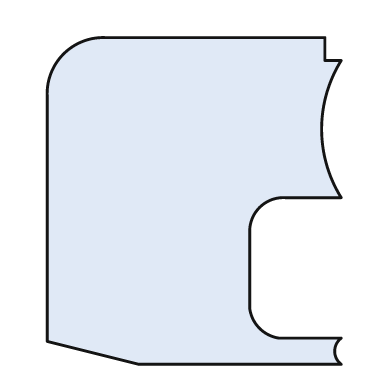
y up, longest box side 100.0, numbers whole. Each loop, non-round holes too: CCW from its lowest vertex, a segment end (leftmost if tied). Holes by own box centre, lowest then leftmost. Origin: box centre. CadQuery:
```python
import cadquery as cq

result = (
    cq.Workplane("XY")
    .moveTo(-17.0, -50.0)
    .lineTo(45.0, -50.0)
    .threePointArc((43.0, -46.0), (45.0, -42.0))
    .lineTo(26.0, -42.0)
    .threePointArc((20.0, -39.0), (17.0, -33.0))
    .lineTo(17.0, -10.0)
    .threePointArc((20.0, -2.0), (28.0, 1.0))
    .lineTo(45.0, 1.0)
    .threePointArc((39.0, 22.0), (45.0, 43.0))
    .lineTo(40.0, 43.0)
    .lineTo(40.0, 50.0)
    .lineTo(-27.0, 50.0)
    .threePointArc((-40.0, 45.0), (-45.0, 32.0))
    .lineTo(-45.0, -43.0)
    .close()
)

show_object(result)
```